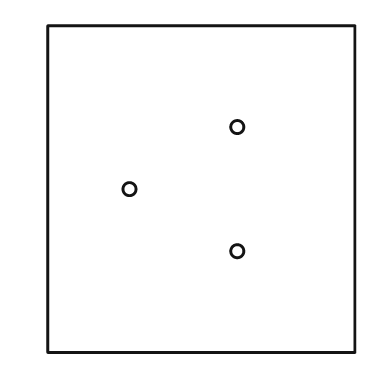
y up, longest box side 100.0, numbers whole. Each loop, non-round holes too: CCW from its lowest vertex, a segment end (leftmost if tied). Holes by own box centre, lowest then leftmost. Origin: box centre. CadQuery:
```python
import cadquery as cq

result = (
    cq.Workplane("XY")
    .moveTo(-47.0, -50.0)
    .lineTo(47.0, -50.0)
    .lineTo(47.0, 50.0)
    .lineTo(-47.0, 50.0)
    .close()
    .moveTo(11.0, -19.0)
    .circle(2.0)
    .moveTo(-22.0, 0.0)
    .circle(2.0)
    .moveTo(11.0, 19.0)
    .circle(2.0)
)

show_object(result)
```